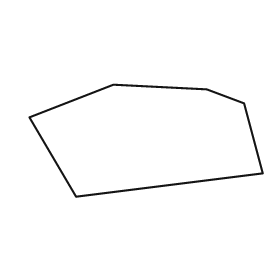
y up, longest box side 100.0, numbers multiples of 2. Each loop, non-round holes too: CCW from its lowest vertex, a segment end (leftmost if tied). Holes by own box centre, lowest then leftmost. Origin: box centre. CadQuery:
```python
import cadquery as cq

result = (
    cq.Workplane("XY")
    .moveTo(-30.0, -24.0)
    .lineTo(50.0, -14.0)
    .lineTo(42.0, 16.0)
    .lineTo(26.0, 22.0)
    .lineTo(-14.0, 24.0)
    .lineTo(-50.0, 10.0)
    .close()
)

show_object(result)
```